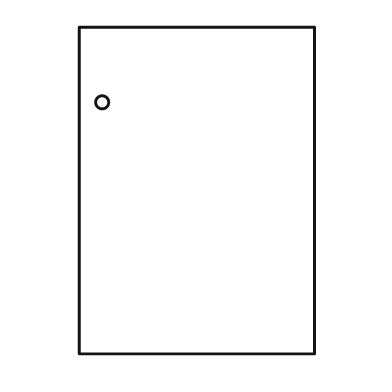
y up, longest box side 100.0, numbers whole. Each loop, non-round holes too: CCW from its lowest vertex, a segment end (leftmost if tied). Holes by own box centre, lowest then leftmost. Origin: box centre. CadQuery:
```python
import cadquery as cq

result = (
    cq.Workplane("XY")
    .moveTo(-36.0, -50.0)
    .lineTo(36.0, -50.0)
    .lineTo(36.0, 50.0)
    .lineTo(-36.0, 50.0)
    .close()
    .moveTo(-29.0, 27.0)
    .circle(2.0)
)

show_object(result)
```